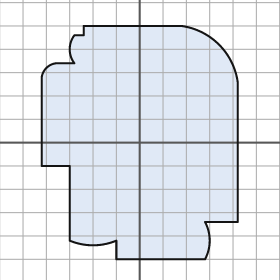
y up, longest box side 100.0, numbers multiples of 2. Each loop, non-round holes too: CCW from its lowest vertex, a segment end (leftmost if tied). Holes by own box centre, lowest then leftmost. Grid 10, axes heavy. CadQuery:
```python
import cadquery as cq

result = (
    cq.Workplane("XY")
    .moveTo(-10.0, -50.0)
    .lineTo(28.0, -50.0)
    .threePointArc((30.0, -42.0), (28.0, -34.0))
    .lineTo(42.0, -34.0)
    .lineTo(42.0, 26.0)
    .threePointArc((34.0, 42.0), (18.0, 50.0))
    .lineTo(-24.0, 50.0)
    .lineTo(-24.0, 46.0)
    .lineTo(-28.0, 46.0)
    .threePointArc((-30.0, 40.0), (-28.0, 34.0))
    .lineTo(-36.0, 34.0)
    .threePointArc((-40.0, 32.0), (-42.0, 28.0))
    .lineTo(-42.0, -10.0)
    .lineTo(-30.0, -10.0)
    .lineTo(-30.0, -42.0)
    .threePointArc((-20.0, -44.0), (-10.0, -42.0))
    .close()
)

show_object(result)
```